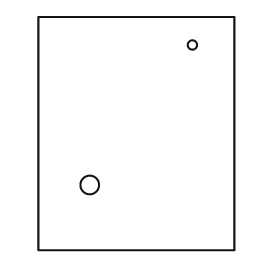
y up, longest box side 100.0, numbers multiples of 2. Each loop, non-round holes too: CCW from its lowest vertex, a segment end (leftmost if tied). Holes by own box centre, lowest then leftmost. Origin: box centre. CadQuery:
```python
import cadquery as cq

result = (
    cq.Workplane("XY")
    .moveTo(-42.0, -50.0)
    .lineTo(42.0, -50.0)
    .lineTo(42.0, 50.0)
    .lineTo(-42.0, 50.0)
    .close()
    .moveTo(-20.0, -22.0)
    .circle(4.0)
    .moveTo(24.0, 38.0)
    .circle(2.0)
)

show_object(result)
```